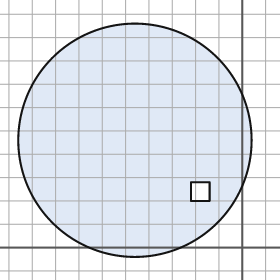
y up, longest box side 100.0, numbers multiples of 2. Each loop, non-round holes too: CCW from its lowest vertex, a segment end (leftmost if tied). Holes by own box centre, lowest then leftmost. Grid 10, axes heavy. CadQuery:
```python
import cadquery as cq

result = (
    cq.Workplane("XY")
    .moveTo(-46.0, 46.0)
    .circle(50.0)
    .moveTo(-22.0, 20.0)
    .lineTo(-14.0, 20.0)
    .lineTo(-14.0, 28.0)
    .lineTo(-22.0, 28.0)
    .close()
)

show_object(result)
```